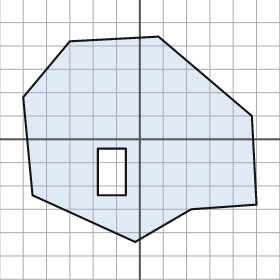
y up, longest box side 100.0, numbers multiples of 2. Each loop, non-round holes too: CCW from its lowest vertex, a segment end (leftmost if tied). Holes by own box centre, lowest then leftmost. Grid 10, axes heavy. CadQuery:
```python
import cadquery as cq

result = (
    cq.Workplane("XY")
    .moveTo(-2.0, -44.0)
    .lineTo(22.0, -30.0)
    .lineTo(50.0, -28.0)
    .lineTo(48.0, 10.0)
    .lineTo(8.0, 44.0)
    .lineTo(-30.0, 42.0)
    .lineTo(-50.0, 18.0)
    .lineTo(-46.0, -24.0)
    .close()
    .moveTo(-18.0, -24.0)
    .lineTo(-6.0, -24.0)
    .lineTo(-6.0, -4.0)
    .lineTo(-18.0, -4.0)
    .close()
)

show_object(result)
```